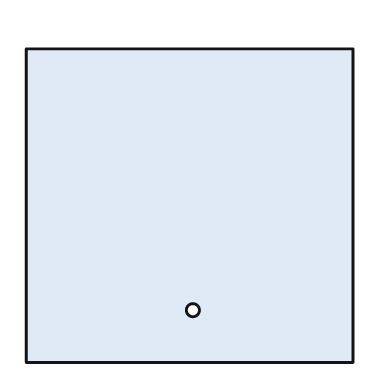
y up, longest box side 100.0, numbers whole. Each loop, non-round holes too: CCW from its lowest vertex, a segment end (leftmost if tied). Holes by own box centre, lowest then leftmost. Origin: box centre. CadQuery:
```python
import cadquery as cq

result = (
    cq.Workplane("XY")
    .moveTo(-50.0, -48.0)
    .lineTo(50.0, -48.0)
    .lineTo(50.0, 48.0)
    .lineTo(-50.0, 48.0)
    .close()
    .moveTo(1.0, -32.0)
    .circle(2.0)
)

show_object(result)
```